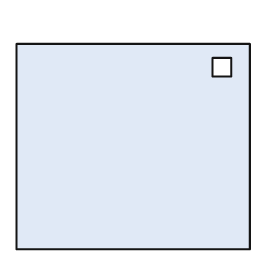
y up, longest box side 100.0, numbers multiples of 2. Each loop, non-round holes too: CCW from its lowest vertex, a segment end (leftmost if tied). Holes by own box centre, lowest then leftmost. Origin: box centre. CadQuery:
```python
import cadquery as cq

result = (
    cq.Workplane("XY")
    .moveTo(-50.0, -44.0)
    .lineTo(50.0, -44.0)
    .lineTo(50.0, 44.0)
    .lineTo(-50.0, 44.0)
    .close()
    .moveTo(34.0, 30.0)
    .lineTo(42.0, 30.0)
    .lineTo(42.0, 38.0)
    .lineTo(34.0, 38.0)
    .close()
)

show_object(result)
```